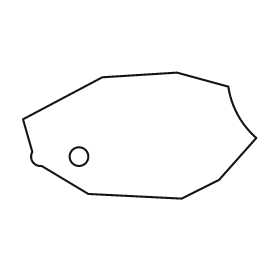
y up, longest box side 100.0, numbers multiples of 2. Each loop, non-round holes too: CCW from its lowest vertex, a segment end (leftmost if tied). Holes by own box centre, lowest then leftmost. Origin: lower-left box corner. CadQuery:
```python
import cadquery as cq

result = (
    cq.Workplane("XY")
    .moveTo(68.0, 0.0)
    .lineTo(84.0, 8.0)
    .lineTo(100.0, 26.0)
    .threePointArc((92.0, 36.0), (88.0, 48.0))
    .lineTo(66.0, 54.0)
    .lineTo(34.0, 52.0)
    .lineTo(0.0, 34.0)
    .lineTo(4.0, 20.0)
    .threePointArc((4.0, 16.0), (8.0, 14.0))
    .lineTo(28.0, 2.0)
    .close()
    .moveTo(24.0, 18.0)
    .circle(4.0)
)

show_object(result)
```